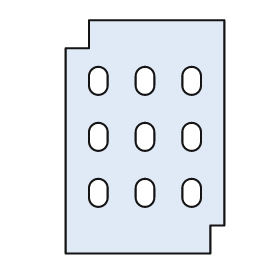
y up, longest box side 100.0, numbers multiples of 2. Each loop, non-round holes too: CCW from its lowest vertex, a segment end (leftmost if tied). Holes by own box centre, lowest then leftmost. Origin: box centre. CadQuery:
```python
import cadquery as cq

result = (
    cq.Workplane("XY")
    .moveTo(-34.0, -50.0)
    .lineTo(28.0, -50.0)
    .lineTo(28.0, -38.0)
    .lineTo(34.0, -38.0)
    .lineTo(34.0, 50.0)
    .lineTo(-24.0, 50.0)
    .lineTo(-24.0, 38.0)
    .lineTo(-34.0, 38.0)
    .close()
    .moveTo(-24.0, -26.0)
    .threePointArc((-20.0, -30.0), (-16.0, -26.0))
    .lineTo(-16.0, -22.0)
    .threePointArc((-20.0, -18.0), (-24.0, -22.0))
    .close()
    .moveTo(-4.0, -26.0)
    .threePointArc((0.0, -30.0), (4.0, -26.0))
    .lineTo(4.0, -22.0)
    .threePointArc((0.0, -18.0), (-4.0, -22.0))
    .close()
    .moveTo(16.0, -26.0)
    .threePointArc((20.0, -30.0), (24.0, -26.0))
    .lineTo(24.0, -22.0)
    .threePointArc((20.0, -18.0), (16.0, -22.0))
    .close()
    .moveTo(-24.0, -2.0)
    .threePointArc((-20.0, -6.0), (-16.0, -2.0))
    .lineTo(-16.0, 2.0)
    .threePointArc((-20.0, 6.0), (-24.0, 2.0))
    .close()
    .moveTo(-4.0, -2.0)
    .threePointArc((0.0, -6.0), (4.0, -2.0))
    .lineTo(4.0, 2.0)
    .threePointArc((0.0, 6.0), (-4.0, 2.0))
    .close()
    .moveTo(16.0, -2.0)
    .threePointArc((20.0, -6.0), (24.0, -2.0))
    .lineTo(24.0, 2.0)
    .threePointArc((20.0, 6.0), (16.0, 2.0))
    .close()
    .moveTo(-24.0, 22.0)
    .threePointArc((-20.0, 18.0), (-16.0, 22.0))
    .lineTo(-16.0, 26.0)
    .threePointArc((-20.0, 30.0), (-24.0, 26.0))
    .close()
    .moveTo(-4.0, 22.0)
    .threePointArc((0.0, 18.0), (4.0, 22.0))
    .lineTo(4.0, 26.0)
    .threePointArc((0.0, 30.0), (-4.0, 26.0))
    .close()
    .moveTo(16.0, 22.0)
    .threePointArc((20.0, 18.0), (24.0, 22.0))
    .lineTo(24.0, 26.0)
    .threePointArc((20.0, 30.0), (16.0, 26.0))
    .close()
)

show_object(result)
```